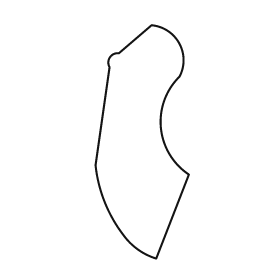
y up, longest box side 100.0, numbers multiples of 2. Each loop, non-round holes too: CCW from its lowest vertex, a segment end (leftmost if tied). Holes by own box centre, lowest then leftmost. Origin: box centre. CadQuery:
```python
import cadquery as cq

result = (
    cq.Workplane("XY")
    .moveTo(6.0, -50.0)
    .lineTo(20.0, -14.0)
    .threePointArc((8.0, 6.0), (16.0, 28.0))
    .threePointArc((16.0, 42.0), (4.0, 50.0))
    .lineTo(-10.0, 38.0)
    .threePointArc((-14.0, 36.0), (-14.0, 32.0))
    .lineTo(-20.0, -10.0)
    .threePointArc((-16.0, -26.0), (-8.0, -40.0))
    .threePointArc((-2.0, -46.0), (6.0, -50.0))
    .close()
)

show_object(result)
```